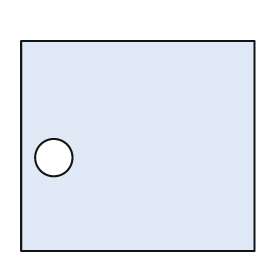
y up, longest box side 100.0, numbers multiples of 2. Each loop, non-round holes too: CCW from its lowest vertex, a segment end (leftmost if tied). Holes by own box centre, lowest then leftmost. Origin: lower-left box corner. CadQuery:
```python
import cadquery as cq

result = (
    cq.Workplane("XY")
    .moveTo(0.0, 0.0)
    .lineTo(100.0, 0.0)
    .lineTo(100.0, 90.0)
    .lineTo(0.0, 90.0)
    .close()
    .moveTo(14.0, 40.0)
    .circle(8.0)
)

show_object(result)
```